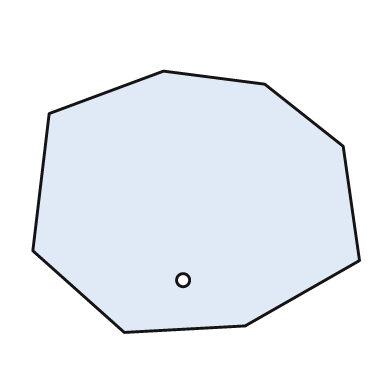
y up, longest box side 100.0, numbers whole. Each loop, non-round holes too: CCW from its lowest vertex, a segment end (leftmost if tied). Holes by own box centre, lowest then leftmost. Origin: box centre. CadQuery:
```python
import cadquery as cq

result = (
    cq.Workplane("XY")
    .moveTo(-22.0, -40.0)
    .lineTo(15.0, -38.0)
    .lineTo(50.0, -18.0)
    .lineTo(45.0, 17.0)
    .lineTo(21.0, 36.0)
    .lineTo(-10.0, 40.0)
    .lineTo(-45.0, 27.0)
    .lineTo(-50.0, -15.0)
    .close()
    .moveTo(-4.0, -24.0)
    .circle(2.0)
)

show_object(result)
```